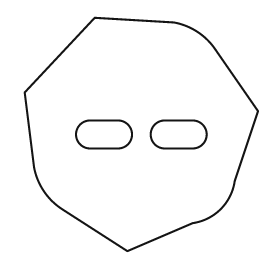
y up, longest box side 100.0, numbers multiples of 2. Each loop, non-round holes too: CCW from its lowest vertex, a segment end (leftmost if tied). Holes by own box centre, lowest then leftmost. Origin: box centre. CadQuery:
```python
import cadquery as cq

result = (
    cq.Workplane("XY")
    .moveTo(-6.0, -50.0)
    .lineTo(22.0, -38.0)
    .threePointArc((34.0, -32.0), (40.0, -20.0))
    .lineTo(50.0, 10.0)
    .lineTo(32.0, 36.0)
    .threePointArc((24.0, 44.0), (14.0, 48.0))
    .lineTo(-20.0, 50.0)
    .lineTo(-50.0, 18.0)
    .lineTo(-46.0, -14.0)
    .threePointArc((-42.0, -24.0), (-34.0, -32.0))
    .close()
    .moveTo(-22.0, -6.0)
    .lineTo(-10.0, -6.0)
    .threePointArc((-4.0, 0.0), (-10.0, 6.0))
    .lineTo(-22.0, 6.0)
    .threePointArc((-28.0, 0.0), (-22.0, -6.0))
    .close()
    .moveTo(10.0, -6.0)
    .lineTo(22.0, -6.0)
    .threePointArc((28.0, 0.0), (22.0, 6.0))
    .lineTo(10.0, 6.0)
    .threePointArc((4.0, 0.0), (10.0, -6.0))
    .close()
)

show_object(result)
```